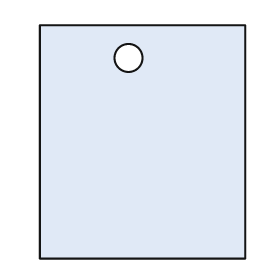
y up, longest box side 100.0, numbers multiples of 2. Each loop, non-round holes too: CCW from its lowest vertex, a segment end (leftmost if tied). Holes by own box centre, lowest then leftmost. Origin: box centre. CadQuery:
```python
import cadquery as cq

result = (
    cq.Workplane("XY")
    .moveTo(-44.0, -50.0)
    .lineTo(44.0, -50.0)
    .lineTo(44.0, 50.0)
    .lineTo(-44.0, 50.0)
    .close()
    .moveTo(-6.0, 36.0)
    .circle(6.0)
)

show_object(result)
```